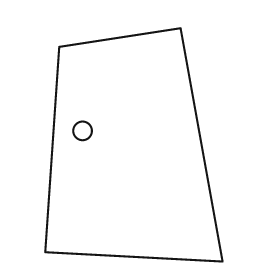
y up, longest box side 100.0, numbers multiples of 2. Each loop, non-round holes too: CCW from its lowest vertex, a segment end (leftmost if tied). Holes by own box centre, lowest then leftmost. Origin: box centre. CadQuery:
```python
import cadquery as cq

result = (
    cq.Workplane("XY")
    .moveTo(38.0, -50.0)
    .lineTo(20.0, 50.0)
    .lineTo(-32.0, 42.0)
    .lineTo(-38.0, -46.0)
    .close()
    .moveTo(-22.0, 6.0)
    .circle(4.0)
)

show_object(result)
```